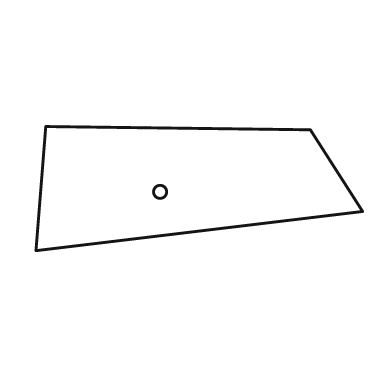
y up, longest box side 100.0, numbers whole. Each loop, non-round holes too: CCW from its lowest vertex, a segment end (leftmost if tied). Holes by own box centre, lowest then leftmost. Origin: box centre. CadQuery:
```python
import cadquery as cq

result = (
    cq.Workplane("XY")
    .moveTo(-50.0, -19.0)
    .lineTo(50.0, -7.0)
    .lineTo(34.0, 18.0)
    .lineTo(-47.0, 19.0)
    .close()
    .moveTo(-12.0, -1.0)
    .circle(2.0)
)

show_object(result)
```